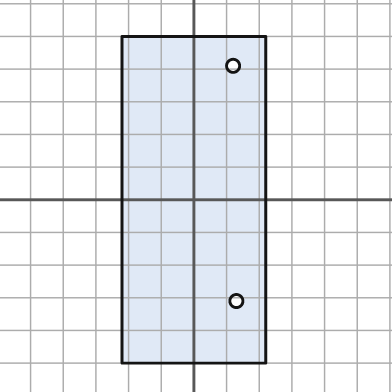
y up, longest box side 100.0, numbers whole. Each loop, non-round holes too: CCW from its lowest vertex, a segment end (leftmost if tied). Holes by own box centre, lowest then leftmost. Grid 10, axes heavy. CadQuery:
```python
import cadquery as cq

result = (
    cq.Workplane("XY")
    .moveTo(-22.0, -50.0)
    .lineTo(22.0, -50.0)
    .lineTo(22.0, 50.0)
    .lineTo(-22.0, 50.0)
    .close()
    .moveTo(13.0, -31.0)
    .circle(2.0)
    .moveTo(12.0, 41.0)
    .circle(2.0)
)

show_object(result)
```